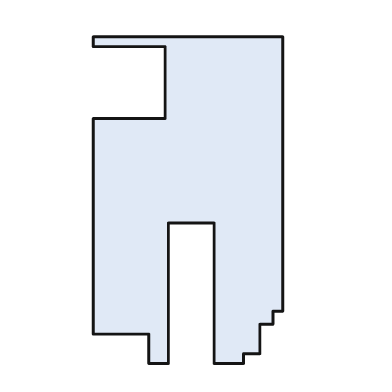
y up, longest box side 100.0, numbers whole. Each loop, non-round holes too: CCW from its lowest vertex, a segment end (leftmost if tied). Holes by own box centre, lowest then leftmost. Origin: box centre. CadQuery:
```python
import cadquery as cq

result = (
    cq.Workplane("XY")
    .moveTo(-12.0, -50.0)
    .lineTo(-6.0, -50.0)
    .lineTo(-6.0, -7.0)
    .lineTo(8.0, -7.0)
    .lineTo(8.0, -50.0)
    .lineTo(17.0, -50.0)
    .lineTo(17.0, -47.0)
    .lineTo(22.0, -47.0)
    .lineTo(22.0, -38.0)
    .lineTo(26.0, -38.0)
    .lineTo(26.0, -34.0)
    .lineTo(29.0, -34.0)
    .lineTo(29.0, 50.0)
    .lineTo(-29.0, 50.0)
    .lineTo(-29.0, 47.0)
    .lineTo(-7.0, 47.0)
    .lineTo(-7.0, 25.0)
    .lineTo(-29.0, 25.0)
    .lineTo(-29.0, -41.0)
    .lineTo(-12.0, -41.0)
    .close()
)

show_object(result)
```